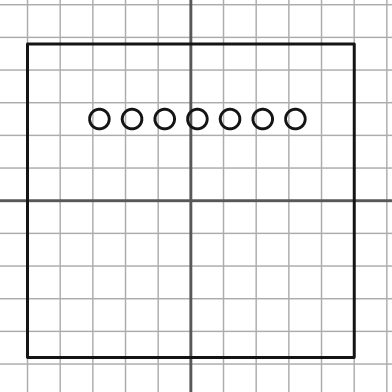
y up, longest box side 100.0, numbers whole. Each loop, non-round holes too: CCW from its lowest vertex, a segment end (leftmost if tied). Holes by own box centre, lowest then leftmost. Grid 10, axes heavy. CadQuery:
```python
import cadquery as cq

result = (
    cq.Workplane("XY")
    .moveTo(-50.0, -48.0)
    .lineTo(50.0, -48.0)
    .lineTo(50.0, 48.0)
    .lineTo(-50.0, 48.0)
    .close()
    .moveTo(-28.0, 25.0)
    .circle(3.0)
    .moveTo(-18.0, 25.0)
    .circle(3.0)
    .moveTo(-8.0, 25.0)
    .circle(3.0)
    .moveTo(2.0, 25.0)
    .circle(3.0)
    .moveTo(12.0, 25.0)
    .circle(3.0)
    .moveTo(22.0, 25.0)
    .circle(3.0)
    .moveTo(32.0, 25.0)
    .circle(3.0)
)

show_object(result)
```